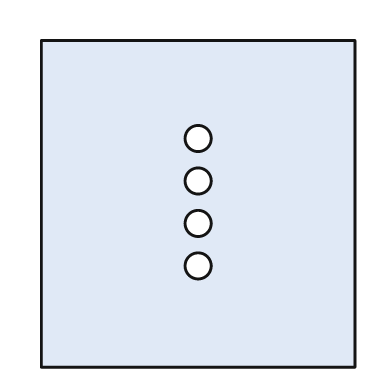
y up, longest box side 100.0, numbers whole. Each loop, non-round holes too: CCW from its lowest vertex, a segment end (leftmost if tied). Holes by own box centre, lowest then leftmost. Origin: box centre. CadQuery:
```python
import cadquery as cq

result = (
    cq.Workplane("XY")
    .moveTo(-48.0, -50.0)
    .lineTo(48.0, -50.0)
    .lineTo(48.0, 50.0)
    .lineTo(-48.0, 50.0)
    .close()
    .moveTo(0.0, -19.0)
    .circle(4.0)
    .moveTo(0.0, -6.0)
    .circle(4.0)
    .moveTo(0.0, 7.0)
    .circle(4.0)
    .moveTo(0.0, 20.0)
    .circle(4.0)
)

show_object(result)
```